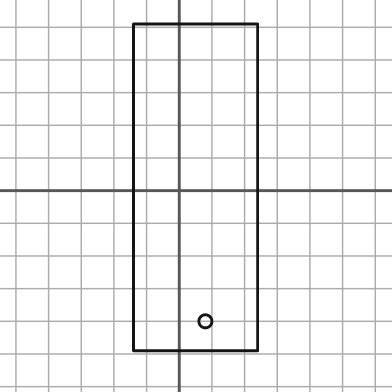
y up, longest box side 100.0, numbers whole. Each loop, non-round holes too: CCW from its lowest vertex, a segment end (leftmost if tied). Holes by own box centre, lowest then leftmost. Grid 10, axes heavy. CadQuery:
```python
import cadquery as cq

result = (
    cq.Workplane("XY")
    .moveTo(-14.0, -49.0)
    .lineTo(24.0, -49.0)
    .lineTo(24.0, 51.0)
    .lineTo(-14.0, 51.0)
    .close()
    .moveTo(8.0, -40.0)
    .circle(2.0)
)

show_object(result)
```